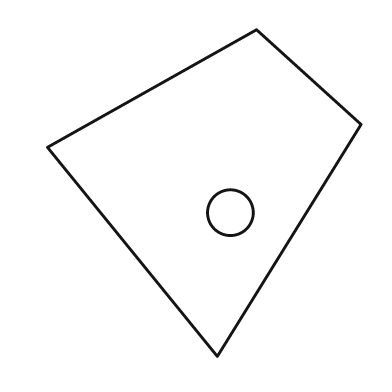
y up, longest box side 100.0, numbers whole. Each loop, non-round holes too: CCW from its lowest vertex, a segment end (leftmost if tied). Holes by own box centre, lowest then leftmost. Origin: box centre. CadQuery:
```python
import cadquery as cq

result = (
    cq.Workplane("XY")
    .moveTo(4.0, -50.0)
    .lineTo(48.0, 21.0)
    .lineTo(16.0, 50.0)
    .lineTo(-48.0, 14.0)
    .close()
    .moveTo(8.0, -6.0)
    .circle(7.0)
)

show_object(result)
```